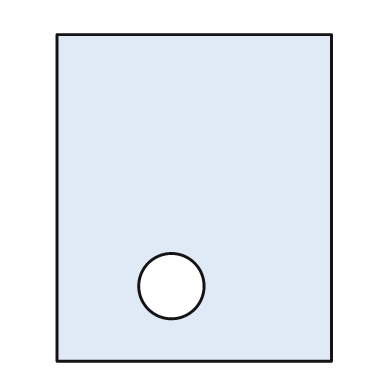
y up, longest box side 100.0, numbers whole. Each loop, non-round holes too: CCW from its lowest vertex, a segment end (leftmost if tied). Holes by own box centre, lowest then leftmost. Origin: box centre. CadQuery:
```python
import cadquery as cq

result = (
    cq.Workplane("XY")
    .moveTo(-42.0, -50.0)
    .lineTo(42.0, -50.0)
    .lineTo(42.0, 50.0)
    .lineTo(-42.0, 50.0)
    .close()
    .moveTo(-7.0, -27.0)
    .circle(10.0)
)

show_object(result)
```